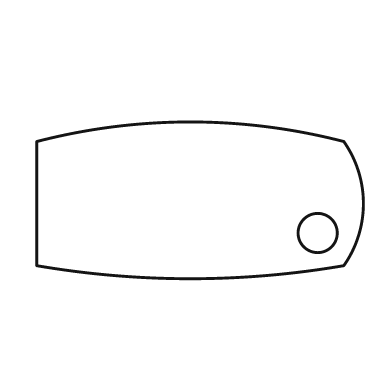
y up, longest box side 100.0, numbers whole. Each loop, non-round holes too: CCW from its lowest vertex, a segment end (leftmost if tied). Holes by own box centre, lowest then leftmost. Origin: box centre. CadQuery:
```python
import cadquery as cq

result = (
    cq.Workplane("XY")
    .moveTo(-50.0, -20.0)
    .threePointArc((-3.0, -24.0), (44.0, -20.0))
    .threePointArc((50.0, -1.0), (44.0, 18.0))
    .threePointArc((-3.0, 24.0), (-50.0, 18.0))
    .close()
    .moveTo(36.0, -10.0)
    .circle(6.0)
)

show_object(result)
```